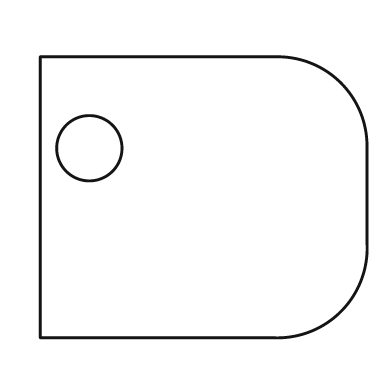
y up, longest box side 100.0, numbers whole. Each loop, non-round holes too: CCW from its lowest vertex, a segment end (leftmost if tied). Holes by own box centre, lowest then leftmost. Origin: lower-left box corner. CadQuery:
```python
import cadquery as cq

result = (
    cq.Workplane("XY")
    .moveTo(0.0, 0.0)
    .lineTo(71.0, 0.0)
    .threePointArc((92.0, 8.0), (100.0, 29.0))
    .lineTo(100.0, 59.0)
    .threePointArc((92.0, 78.0), (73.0, 86.0))
    .lineTo(0.0, 86.0)
    .close()
    .moveTo(15.0, 58.0)
    .circle(10.0)
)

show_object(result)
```